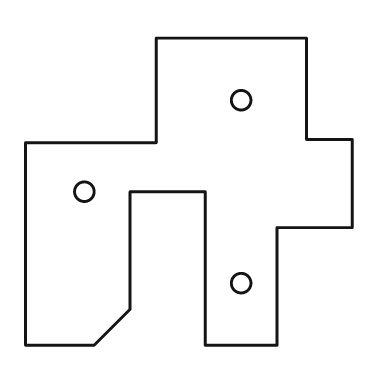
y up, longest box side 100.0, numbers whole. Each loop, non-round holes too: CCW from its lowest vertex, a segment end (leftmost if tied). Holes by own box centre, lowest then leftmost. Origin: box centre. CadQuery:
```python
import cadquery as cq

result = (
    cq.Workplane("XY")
    .moveTo(-50.0, -47.0)
    .lineTo(-29.0, -47.0)
    .lineTo(-18.0, -36.0)
    .lineTo(-18.0, 0.0)
    .lineTo(5.0, 0.0)
    .lineTo(5.0, -47.0)
    .lineTo(27.0, -47.0)
    .lineTo(27.0, -11.0)
    .lineTo(50.0, -11.0)
    .lineTo(50.0, 16.0)
    .lineTo(36.0, 16.0)
    .lineTo(36.0, 47.0)
    .lineTo(-10.0, 47.0)
    .lineTo(-10.0, 15.0)
    .lineTo(-50.0, 15.0)
    .close()
    .moveTo(16.0, -28.0)
    .circle(3.0)
    .moveTo(-32.0, 0.0)
    .circle(3.0)
    .moveTo(16.0, 28.0)
    .circle(3.0)
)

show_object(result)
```